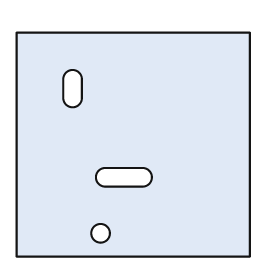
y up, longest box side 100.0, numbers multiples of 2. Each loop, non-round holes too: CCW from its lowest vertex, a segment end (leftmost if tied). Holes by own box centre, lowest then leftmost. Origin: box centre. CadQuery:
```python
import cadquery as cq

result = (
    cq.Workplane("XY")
    .moveTo(-50.0, -48.0)
    .lineTo(50.0, -48.0)
    .lineTo(50.0, 48.0)
    .lineTo(-50.0, 48.0)
    .close()
    .moveTo(-14.0, -38.0)
    .circle(4.0)
    .moveTo(-12.0, -18.0)
    .lineTo(4.0, -18.0)
    .threePointArc((8.0, -14.0), (4.0, -10.0))
    .lineTo(-12.0, -10.0)
    .threePointArc((-16.0, -14.0), (-12.0, -18.0))
    .close()
    .moveTo(-30.0, 20.0)
    .threePointArc((-26.0, 16.0), (-22.0, 20.0))
    .lineTo(-22.0, 28.0)
    .threePointArc((-26.0, 32.0), (-30.0, 28.0))
    .close()
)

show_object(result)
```